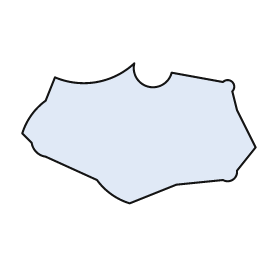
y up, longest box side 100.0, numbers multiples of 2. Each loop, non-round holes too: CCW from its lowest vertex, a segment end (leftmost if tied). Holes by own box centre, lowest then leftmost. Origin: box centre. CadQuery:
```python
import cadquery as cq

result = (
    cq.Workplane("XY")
    .moveTo(-4.0, -30.0)
    .lineTo(16.0, -22.0)
    .lineTo(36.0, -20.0)
    .threePointArc((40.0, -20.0), (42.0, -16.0))
    .lineTo(50.0, -6.0)
    .lineTo(42.0, 10.0)
    .lineTo(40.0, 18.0)
    .threePointArc((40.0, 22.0), (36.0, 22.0))
    .lineTo(14.0, 26.0)
    .threePointArc((4.0, 20.0), (-2.0, 30.0))
    .threePointArc((-18.0, 22.0), (-36.0, 24.0))
    .lineTo(-40.0, 14.0)
    .threePointArc((-46.0, 8.0), (-50.0, 0.0))
    .lineTo(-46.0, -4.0)
    .threePointArc((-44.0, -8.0), (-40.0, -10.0))
    .lineTo(-18.0, -20.0)
    .threePointArc((-12.0, -26.0), (-4.0, -30.0))
    .close()
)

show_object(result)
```